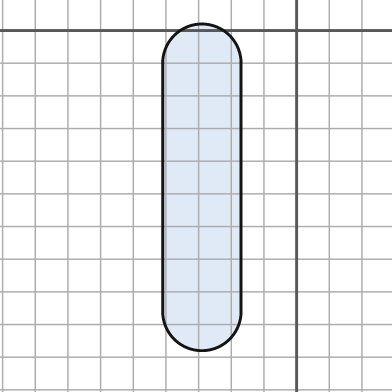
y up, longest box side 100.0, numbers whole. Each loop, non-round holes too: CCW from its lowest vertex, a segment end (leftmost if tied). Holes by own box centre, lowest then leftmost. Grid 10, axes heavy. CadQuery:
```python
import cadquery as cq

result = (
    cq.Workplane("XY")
    .moveTo(-41.0, -86.0)
    .threePointArc((-29.0, -98.0), (-17.0, -86.0))
    .lineTo(-17.0, -10.0)
    .threePointArc((-29.0, 2.0), (-41.0, -10.0))
    .close()
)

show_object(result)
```